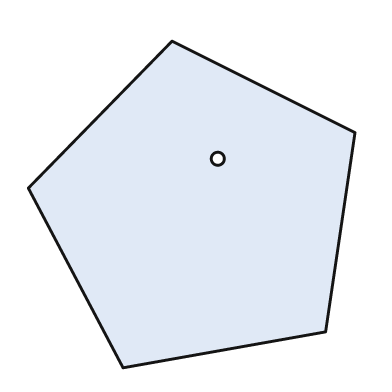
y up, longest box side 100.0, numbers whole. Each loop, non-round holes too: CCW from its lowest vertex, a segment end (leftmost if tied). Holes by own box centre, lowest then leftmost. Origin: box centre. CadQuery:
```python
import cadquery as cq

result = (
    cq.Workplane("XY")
    .moveTo(-21.0, -50.0)
    .lineTo(41.0, -39.0)
    .lineTo(50.0, 22.0)
    .lineTo(-6.0, 50.0)
    .lineTo(-50.0, 5.0)
    .close()
    .moveTo(8.0, 14.0)
    .circle(2.0)
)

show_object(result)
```